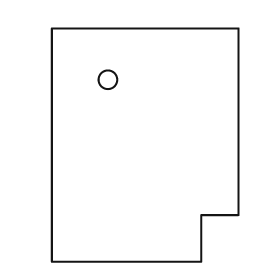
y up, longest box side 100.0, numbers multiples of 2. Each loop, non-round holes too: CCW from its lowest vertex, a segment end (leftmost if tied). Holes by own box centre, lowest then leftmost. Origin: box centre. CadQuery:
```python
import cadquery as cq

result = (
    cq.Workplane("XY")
    .moveTo(-40.0, -50.0)
    .lineTo(24.0, -50.0)
    .lineTo(24.0, -30.0)
    .lineTo(40.0, -30.0)
    .lineTo(40.0, 50.0)
    .lineTo(-40.0, 50.0)
    .close()
    .moveTo(-16.0, 28.0)
    .circle(4.0)
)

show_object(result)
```